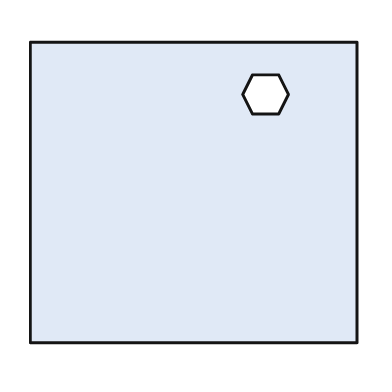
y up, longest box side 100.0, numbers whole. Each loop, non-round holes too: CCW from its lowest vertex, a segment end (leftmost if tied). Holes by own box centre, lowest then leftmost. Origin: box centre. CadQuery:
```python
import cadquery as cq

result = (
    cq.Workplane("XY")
    .moveTo(-50.0, -46.0)
    .lineTo(50.0, -46.0)
    .lineTo(50.0, 46.0)
    .lineTo(-50.0, 46.0)
    .close()
    .moveTo(18.0, 24.0)
    .lineTo(26.0, 24.0)
    .lineTo(29.0, 30.0)
    .lineTo(26.0, 36.0)
    .lineTo(18.0, 36.0)
    .lineTo(15.0, 30.0)
    .close()
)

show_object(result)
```